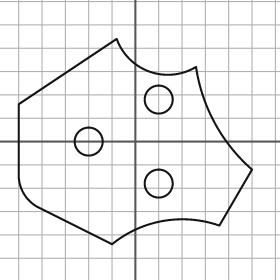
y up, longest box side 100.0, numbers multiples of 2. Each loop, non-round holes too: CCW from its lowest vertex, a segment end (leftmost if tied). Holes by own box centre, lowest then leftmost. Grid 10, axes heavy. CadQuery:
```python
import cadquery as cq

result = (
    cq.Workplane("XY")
    .moveTo(-10.0, -44.0)
    .threePointArc((12.0, -34.0), (36.0, -36.0))
    .lineTo(50.0, -12.0)
    .threePointArc((34.0, 8.0), (26.0, 32.0))
    .threePointArc((6.0, 30.0), (-8.0, 44.0))
    .lineTo(-50.0, 16.0)
    .lineTo(-50.0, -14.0)
    .threePointArc((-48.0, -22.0), (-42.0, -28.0))
    .close()
    .moveTo(10.0, -18.0)
    .circle(6.0)
    .moveTo(-20.0, 0.0)
    .circle(6.0)
    .moveTo(10.0, 18.0)
    .circle(6.0)
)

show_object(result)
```